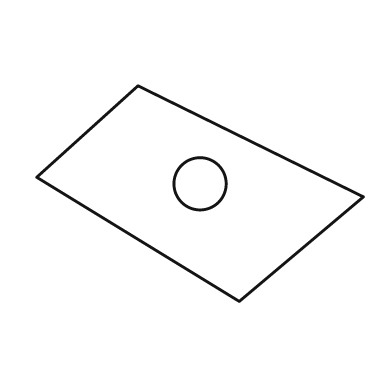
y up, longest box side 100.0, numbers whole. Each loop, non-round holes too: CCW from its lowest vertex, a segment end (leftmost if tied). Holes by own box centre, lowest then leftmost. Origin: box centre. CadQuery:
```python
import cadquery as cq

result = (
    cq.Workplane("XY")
    .moveTo(12.0, -33.0)
    .lineTo(50.0, -1.0)
    .lineTo(-19.0, 33.0)
    .lineTo(-50.0, 5.0)
    .close()
    .moveTo(0.0, 3.0)
    .circle(8.0)
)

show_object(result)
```